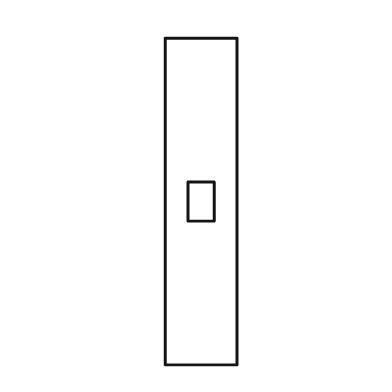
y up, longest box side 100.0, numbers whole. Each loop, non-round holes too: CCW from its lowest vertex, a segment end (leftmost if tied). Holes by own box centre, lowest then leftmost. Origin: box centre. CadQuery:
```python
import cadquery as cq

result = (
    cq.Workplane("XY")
    .moveTo(-11.0, -50.0)
    .lineTo(11.0, -50.0)
    .lineTo(11.0, 50.0)
    .lineTo(-11.0, 50.0)
    .close()
    .moveTo(-4.0, -6.0)
    .lineTo(4.0, -6.0)
    .lineTo(4.0, 6.0)
    .lineTo(-4.0, 6.0)
    .close()
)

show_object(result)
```